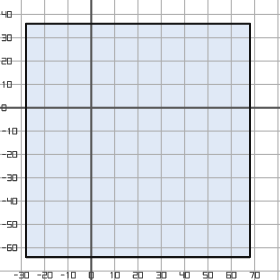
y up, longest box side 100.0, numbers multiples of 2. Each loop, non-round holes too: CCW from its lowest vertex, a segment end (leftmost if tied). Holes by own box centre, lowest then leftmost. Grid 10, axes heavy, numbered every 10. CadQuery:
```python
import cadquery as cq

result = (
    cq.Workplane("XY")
    .moveTo(-28.0, -64.0)
    .lineTo(68.0, -64.0)
    .lineTo(68.0, 36.0)
    .lineTo(-28.0, 36.0)
    .close()
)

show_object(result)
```